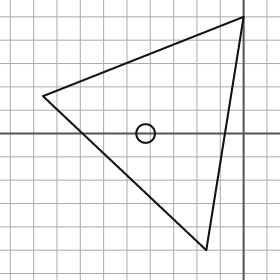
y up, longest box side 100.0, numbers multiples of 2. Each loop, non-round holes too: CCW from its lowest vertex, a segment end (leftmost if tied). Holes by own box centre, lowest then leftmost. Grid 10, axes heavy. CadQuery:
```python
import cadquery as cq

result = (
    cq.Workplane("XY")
    .moveTo(-16.0, -50.0)
    .lineTo(0.0, 50.0)
    .lineTo(-86.0, 16.0)
    .close()
    .moveTo(-42.0, 0.0)
    .circle(4.0)
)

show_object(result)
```